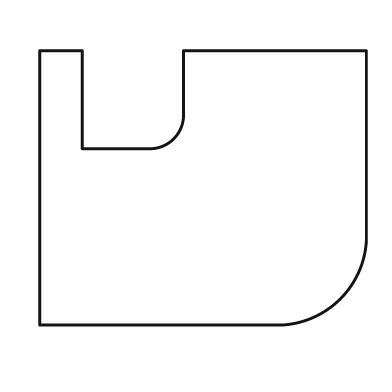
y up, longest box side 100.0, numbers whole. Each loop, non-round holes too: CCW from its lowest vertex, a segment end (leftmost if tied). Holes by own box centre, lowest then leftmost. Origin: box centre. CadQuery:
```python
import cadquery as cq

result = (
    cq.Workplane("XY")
    .moveTo(-50.0, -42.0)
    .lineTo(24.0, -42.0)
    .threePointArc((42.0, -34.0), (50.0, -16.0))
    .lineTo(50.0, 42.0)
    .lineTo(-6.0, 42.0)
    .lineTo(-6.0, 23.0)
    .threePointArc((-9.0, 15.0), (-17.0, 12.0))
    .lineTo(-37.0, 12.0)
    .lineTo(-37.0, 42.0)
    .lineTo(-50.0, 42.0)
    .close()
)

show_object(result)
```